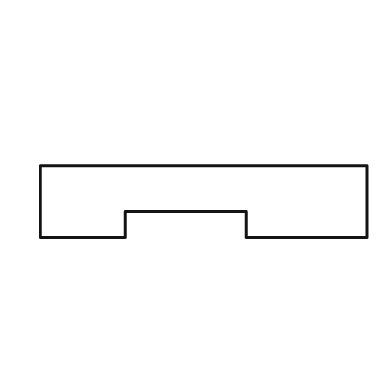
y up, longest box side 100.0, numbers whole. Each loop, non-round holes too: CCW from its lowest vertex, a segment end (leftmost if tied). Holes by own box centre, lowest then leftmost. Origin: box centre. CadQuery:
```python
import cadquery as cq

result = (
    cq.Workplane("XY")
    .moveTo(-50.0, -11.0)
    .lineTo(-24.0, -11.0)
    .lineTo(-24.0, -3.0)
    .lineTo(13.0, -3.0)
    .lineTo(13.0, -11.0)
    .lineTo(50.0, -11.0)
    .lineTo(50.0, 11.0)
    .lineTo(-50.0, 11.0)
    .close()
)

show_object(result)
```